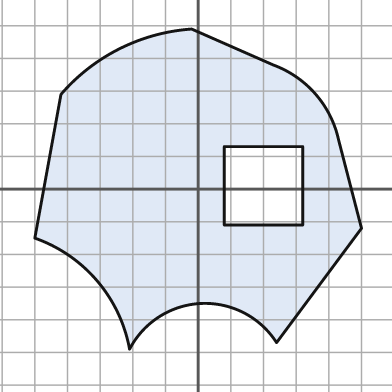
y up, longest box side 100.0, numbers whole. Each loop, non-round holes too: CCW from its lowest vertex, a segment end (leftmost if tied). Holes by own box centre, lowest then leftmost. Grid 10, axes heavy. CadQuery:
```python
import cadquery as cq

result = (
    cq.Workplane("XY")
    .moveTo(-21.0, -49.0)
    .threePointArc((1.0, -35.0), (24.0, -47.0))
    .lineTo(50.0, -12.0)
    .lineTo(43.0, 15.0)
    .threePointArc((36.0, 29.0), (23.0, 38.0))
    .lineTo(-2.0, 49.0)
    .threePointArc((-24.0, 43.0), (-42.0, 29.0))
    .lineTo(-50.0, -15.0)
    .threePointArc((-31.0, -28.0), (-21.0, -49.0))
    .close()
    .moveTo(8.0, -11.0)
    .lineTo(32.0, -11.0)
    .lineTo(32.0, 13.0)
    .lineTo(8.0, 13.0)
    .close()
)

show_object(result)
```